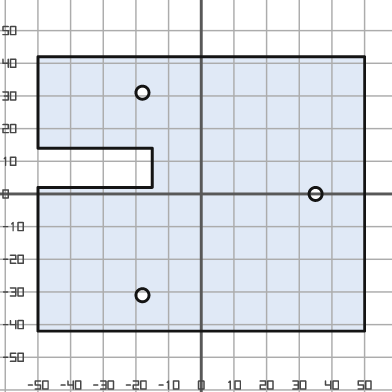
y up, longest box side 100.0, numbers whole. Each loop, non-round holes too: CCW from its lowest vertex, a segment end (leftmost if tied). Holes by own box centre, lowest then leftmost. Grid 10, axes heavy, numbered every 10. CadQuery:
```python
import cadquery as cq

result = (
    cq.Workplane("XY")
    .moveTo(-50.0, -42.0)
    .lineTo(50.0, -42.0)
    .lineTo(50.0, 42.0)
    .lineTo(-50.0, 42.0)
    .lineTo(-50.0, 14.0)
    .lineTo(-15.0, 14.0)
    .lineTo(-15.0, 2.0)
    .lineTo(-50.0, 2.0)
    .close()
    .moveTo(-18.0, -31.0)
    .circle(2.0)
    .moveTo(35.0, 0.0)
    .circle(2.0)
    .moveTo(-18.0, 31.0)
    .circle(2.0)
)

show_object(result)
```